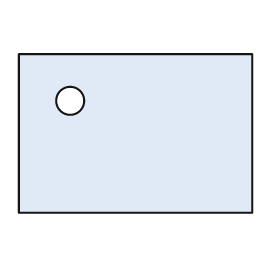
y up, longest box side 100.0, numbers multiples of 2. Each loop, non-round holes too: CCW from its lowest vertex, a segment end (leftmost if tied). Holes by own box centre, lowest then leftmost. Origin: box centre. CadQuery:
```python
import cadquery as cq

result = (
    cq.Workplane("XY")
    .moveTo(-50.0, -34.0)
    .lineTo(50.0, -34.0)
    .lineTo(50.0, 34.0)
    .lineTo(-50.0, 34.0)
    .close()
    .moveTo(-28.0, 14.0)
    .circle(6.0)
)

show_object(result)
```